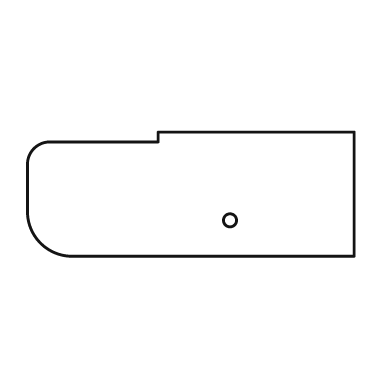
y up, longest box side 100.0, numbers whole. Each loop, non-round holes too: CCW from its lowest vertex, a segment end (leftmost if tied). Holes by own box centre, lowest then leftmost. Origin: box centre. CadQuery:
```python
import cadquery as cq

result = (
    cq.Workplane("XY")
    .moveTo(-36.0, -19.0)
    .lineTo(50.0, -19.0)
    .lineTo(50.0, 19.0)
    .lineTo(-10.0, 19.0)
    .lineTo(-10.0, 16.0)
    .lineTo(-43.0, 16.0)
    .threePointArc((-48.0, 14.0), (-50.0, 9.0))
    .lineTo(-50.0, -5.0)
    .threePointArc((-46.0, -15.0), (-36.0, -19.0))
    .close()
    .moveTo(12.0, -8.0)
    .circle(2.0)
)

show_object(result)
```